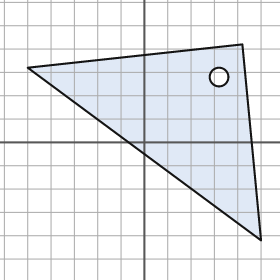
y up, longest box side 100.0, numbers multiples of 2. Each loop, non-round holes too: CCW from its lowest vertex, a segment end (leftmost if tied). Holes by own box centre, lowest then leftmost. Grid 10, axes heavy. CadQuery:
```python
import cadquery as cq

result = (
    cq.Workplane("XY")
    .moveTo(50.0, -42.0)
    .lineTo(42.0, 42.0)
    .lineTo(-50.0, 32.0)
    .close()
    .moveTo(32.0, 28.0)
    .circle(4.0)
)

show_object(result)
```